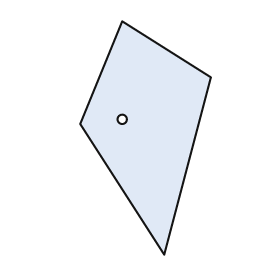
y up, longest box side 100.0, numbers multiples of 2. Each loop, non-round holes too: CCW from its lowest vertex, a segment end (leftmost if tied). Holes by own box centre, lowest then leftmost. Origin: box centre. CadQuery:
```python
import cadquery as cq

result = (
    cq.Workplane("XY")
    .moveTo(8.0, -50.0)
    .lineTo(28.0, 26.0)
    .lineTo(-10.0, 50.0)
    .lineTo(-28.0, 6.0)
    .close()
    .moveTo(-10.0, 8.0)
    .circle(2.0)
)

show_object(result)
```